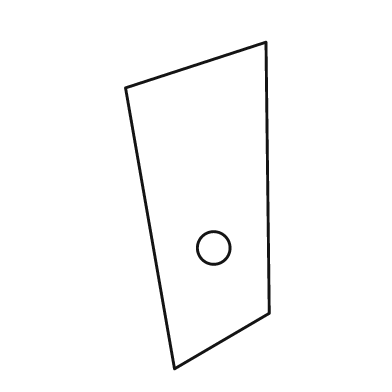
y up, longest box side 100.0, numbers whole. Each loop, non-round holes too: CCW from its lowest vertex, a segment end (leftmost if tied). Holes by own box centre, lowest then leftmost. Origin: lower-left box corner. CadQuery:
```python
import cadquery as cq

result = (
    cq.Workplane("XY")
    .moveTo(15.0, 0.0)
    .lineTo(44.0, 17.0)
    .lineTo(43.0, 100.0)
    .lineTo(0.0, 86.0)
    .close()
    .moveTo(27.0, 37.0)
    .circle(5.0)
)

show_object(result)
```